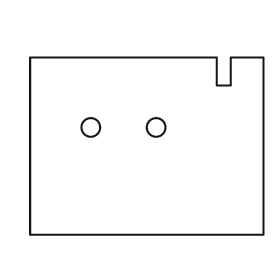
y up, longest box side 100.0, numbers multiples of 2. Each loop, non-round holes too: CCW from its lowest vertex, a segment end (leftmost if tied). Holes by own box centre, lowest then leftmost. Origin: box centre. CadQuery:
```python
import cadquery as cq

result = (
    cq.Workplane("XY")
    .moveTo(-50.0, -38.0)
    .lineTo(50.0, -38.0)
    .lineTo(50.0, 38.0)
    .lineTo(36.0, 38.0)
    .lineTo(36.0, 26.0)
    .lineTo(30.0, 26.0)
    .lineTo(30.0, 38.0)
    .lineTo(-50.0, 38.0)
    .close()
    .moveTo(-24.0, 8.0)
    .circle(4.0)
    .moveTo(4.0, 8.0)
    .circle(4.0)
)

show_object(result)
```